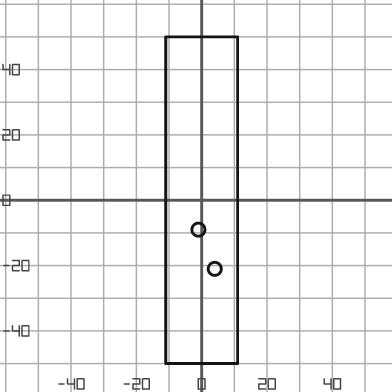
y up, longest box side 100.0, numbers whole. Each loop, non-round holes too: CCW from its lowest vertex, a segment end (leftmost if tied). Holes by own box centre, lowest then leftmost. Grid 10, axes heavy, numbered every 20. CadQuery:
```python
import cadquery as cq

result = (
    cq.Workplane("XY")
    .moveTo(-11.0, -50.0)
    .lineTo(11.0, -50.0)
    .lineTo(11.0, 50.0)
    .lineTo(-11.0, 50.0)
    .close()
    .moveTo(4.0, -21.0)
    .circle(2.0)
    .moveTo(-1.0, -9.0)
    .circle(2.0)
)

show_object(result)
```